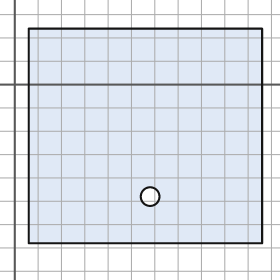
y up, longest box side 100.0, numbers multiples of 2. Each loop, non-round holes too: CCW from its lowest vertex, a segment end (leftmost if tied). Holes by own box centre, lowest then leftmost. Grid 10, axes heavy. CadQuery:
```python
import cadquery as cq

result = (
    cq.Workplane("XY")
    .moveTo(6.0, -68.0)
    .lineTo(106.0, -68.0)
    .lineTo(106.0, 24.0)
    .lineTo(6.0, 24.0)
    .close()
    .moveTo(58.0, -48.0)
    .circle(4.0)
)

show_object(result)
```